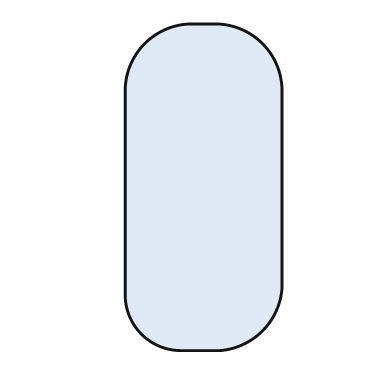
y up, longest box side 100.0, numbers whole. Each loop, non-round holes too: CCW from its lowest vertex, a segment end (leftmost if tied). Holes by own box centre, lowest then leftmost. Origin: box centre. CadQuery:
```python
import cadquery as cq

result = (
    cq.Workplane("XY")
    .moveTo(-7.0, -50.0)
    .lineTo(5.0, -50.0)
    .threePointArc((18.0, -44.0), (24.0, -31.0))
    .lineTo(24.0, 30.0)
    .threePointArc((18.0, 44.0), (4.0, 50.0))
    .lineTo(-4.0, 50.0)
    .threePointArc((-18.0, 44.0), (-24.0, 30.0))
    .lineTo(-24.0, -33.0)
    .threePointArc((-19.0, -45.0), (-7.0, -50.0))
    .close()
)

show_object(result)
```